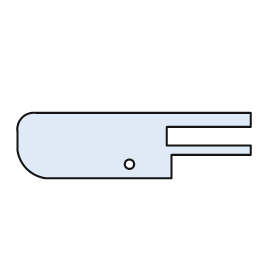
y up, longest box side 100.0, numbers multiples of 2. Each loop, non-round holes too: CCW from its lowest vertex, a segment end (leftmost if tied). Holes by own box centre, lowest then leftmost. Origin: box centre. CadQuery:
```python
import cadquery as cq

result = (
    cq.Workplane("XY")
    .moveTo(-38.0, -14.0)
    .lineTo(16.0, -14.0)
    .lineTo(16.0, -4.0)
    .lineTo(50.0, -4.0)
    .lineTo(50.0, 0.0)
    .lineTo(14.0, 0.0)
    .lineTo(14.0, 8.0)
    .lineTo(50.0, 8.0)
    .lineTo(50.0, 14.0)
    .lineTo(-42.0, 14.0)
    .threePointArc((-48.0, 12.0), (-50.0, 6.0))
    .lineTo(-50.0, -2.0)
    .threePointArc((-46.0, -10.0), (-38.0, -14.0))
    .close()
    .moveTo(-2.0, -8.0)
    .circle(2.0)
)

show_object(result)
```